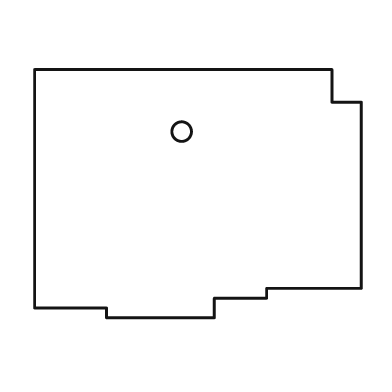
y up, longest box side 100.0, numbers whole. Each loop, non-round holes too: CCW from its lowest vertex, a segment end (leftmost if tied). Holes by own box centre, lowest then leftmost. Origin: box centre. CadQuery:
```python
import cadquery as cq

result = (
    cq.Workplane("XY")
    .moveTo(-28.0, -38.0)
    .lineTo(5.0, -38.0)
    .lineTo(5.0, -32.0)
    .lineTo(21.0, -32.0)
    .lineTo(21.0, -29.0)
    .lineTo(50.0, -29.0)
    .lineTo(50.0, 28.0)
    .lineTo(41.0, 28.0)
    .lineTo(41.0, 38.0)
    .lineTo(-50.0, 38.0)
    .lineTo(-50.0, -35.0)
    .lineTo(-28.0, -35.0)
    .close()
    .moveTo(-5.0, 19.0)
    .circle(3.0)
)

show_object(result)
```